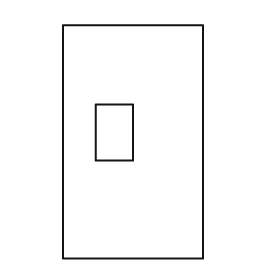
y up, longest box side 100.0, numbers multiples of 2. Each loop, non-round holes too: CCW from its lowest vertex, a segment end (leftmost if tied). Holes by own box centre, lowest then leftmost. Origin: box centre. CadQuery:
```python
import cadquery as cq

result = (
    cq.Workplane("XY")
    .moveTo(-30.0, -50.0)
    .lineTo(30.0, -50.0)
    .lineTo(30.0, 50.0)
    .lineTo(-30.0, 50.0)
    .close()
    .moveTo(-16.0, -8.0)
    .lineTo(0.0, -8.0)
    .lineTo(0.0, 16.0)
    .lineTo(-16.0, 16.0)
    .close()
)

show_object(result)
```